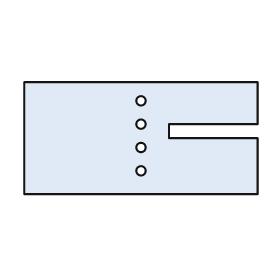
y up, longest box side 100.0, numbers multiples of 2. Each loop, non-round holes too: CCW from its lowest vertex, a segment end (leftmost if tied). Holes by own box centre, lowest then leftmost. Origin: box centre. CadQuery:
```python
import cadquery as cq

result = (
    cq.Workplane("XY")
    .moveTo(-50.0, -24.0)
    .lineTo(50.0, -24.0)
    .lineTo(50.0, 0.0)
    .lineTo(12.0, 0.0)
    .lineTo(12.0, 6.0)
    .lineTo(50.0, 6.0)
    .lineTo(50.0, 24.0)
    .lineTo(-50.0, 24.0)
    .close()
    .moveTo(0.0, -14.0)
    .circle(2.0)
    .moveTo(0.0, -4.0)
    .circle(2.0)
    .moveTo(0.0, 6.0)
    .circle(2.0)
    .moveTo(0.0, 16.0)
    .circle(2.0)
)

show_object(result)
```